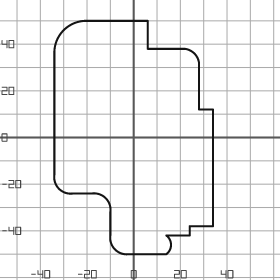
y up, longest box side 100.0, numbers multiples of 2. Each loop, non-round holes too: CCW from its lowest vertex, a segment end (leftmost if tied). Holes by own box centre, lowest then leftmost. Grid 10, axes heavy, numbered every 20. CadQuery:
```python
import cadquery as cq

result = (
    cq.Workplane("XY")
    .moveTo(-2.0, -50.0)
    .lineTo(14.0, -50.0)
    .threePointArc((16.0, -46.0), (14.0, -42.0))
    .lineTo(24.0, -42.0)
    .lineTo(24.0, -38.0)
    .lineTo(34.0, -38.0)
    .lineTo(34.0, 12.0)
    .lineTo(28.0, 12.0)
    .lineTo(28.0, 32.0)
    .threePointArc((26.0, 36.0), (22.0, 38.0))
    .lineTo(6.0, 38.0)
    .lineTo(6.0, 50.0)
    .lineTo(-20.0, 50.0)
    .threePointArc((-30.0, 46.0), (-34.0, 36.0))
    .lineTo(-34.0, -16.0)
    .threePointArc((-32.0, -22.0), (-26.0, -24.0))
    .lineTo(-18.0, -24.0)
    .threePointArc((-12.0, -26.0), (-10.0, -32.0))
    .lineTo(-10.0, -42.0)
    .threePointArc((-8.0, -48.0), (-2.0, -50.0))
    .close()
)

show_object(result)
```